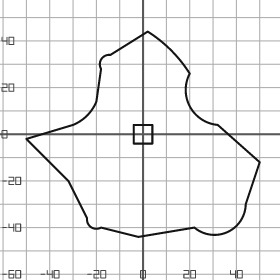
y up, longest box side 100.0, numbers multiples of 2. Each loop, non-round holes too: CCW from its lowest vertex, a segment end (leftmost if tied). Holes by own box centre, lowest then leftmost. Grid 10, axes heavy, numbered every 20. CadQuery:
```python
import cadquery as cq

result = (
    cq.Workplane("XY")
    .moveTo(-2.0, -44.0)
    .lineTo(22.0, -40.0)
    .threePointArc((36.0, -42.0), (44.0, -30.0))
    .lineTo(50.0, -12.0)
    .lineTo(32.0, 4.0)
    .threePointArc((20.0, 12.0), (20.0, 26.0))
    .threePointArc((12.0, 36.0), (2.0, 44.0))
    .lineTo(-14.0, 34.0)
    .threePointArc((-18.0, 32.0), (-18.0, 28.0))
    .lineTo(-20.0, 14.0)
    .threePointArc((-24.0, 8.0), (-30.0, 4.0))
    .lineTo(-50.0, -2.0)
    .lineTo(-32.0, -20.0)
    .lineTo(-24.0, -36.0)
    .threePointArc((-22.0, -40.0), (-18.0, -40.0))
    .close()
    .moveTo(-4.0, -4.0)
    .lineTo(4.0, -4.0)
    .lineTo(4.0, 4.0)
    .lineTo(-4.0, 4.0)
    .close()
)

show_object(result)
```